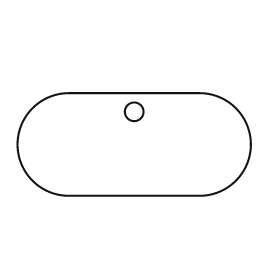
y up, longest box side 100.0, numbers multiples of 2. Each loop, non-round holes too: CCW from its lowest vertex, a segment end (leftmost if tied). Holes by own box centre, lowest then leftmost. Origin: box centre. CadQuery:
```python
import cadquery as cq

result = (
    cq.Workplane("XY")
    .moveTo(-28.0, -22.0)
    .lineTo(28.0, -22.0)
    .threePointArc((50.0, 0.0), (28.0, 22.0))
    .lineTo(-28.0, 22.0)
    .threePointArc((-50.0, 0.0), (-28.0, -22.0))
    .close()
    .moveTo(0.0, 14.0)
    .circle(4.0)
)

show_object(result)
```